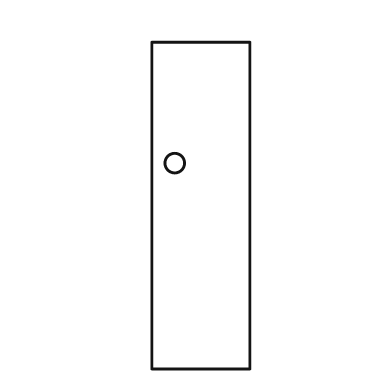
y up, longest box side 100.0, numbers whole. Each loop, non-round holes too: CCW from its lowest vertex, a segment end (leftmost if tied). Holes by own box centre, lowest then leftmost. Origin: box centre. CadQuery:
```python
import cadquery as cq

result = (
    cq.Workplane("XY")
    .moveTo(-15.0, -50.0)
    .lineTo(15.0, -50.0)
    .lineTo(15.0, 50.0)
    .lineTo(-15.0, 50.0)
    .close()
    .moveTo(-8.0, 13.0)
    .circle(3.0)
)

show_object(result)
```